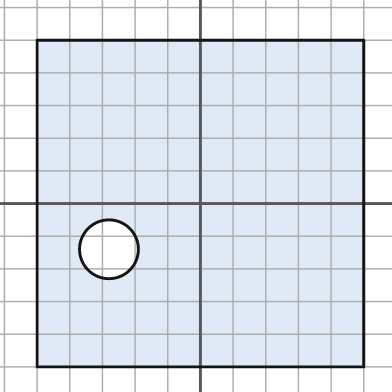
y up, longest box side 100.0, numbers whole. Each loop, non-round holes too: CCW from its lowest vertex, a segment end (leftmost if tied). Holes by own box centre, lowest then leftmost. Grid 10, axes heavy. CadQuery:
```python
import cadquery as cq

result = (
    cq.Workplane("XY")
    .moveTo(-50.0, -50.0)
    .lineTo(50.0, -50.0)
    .lineTo(50.0, 50.0)
    .lineTo(-50.0, 50.0)
    .close()
    .moveTo(-28.0, -14.0)
    .circle(9.0)
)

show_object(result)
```